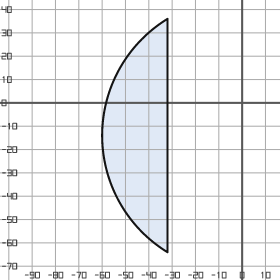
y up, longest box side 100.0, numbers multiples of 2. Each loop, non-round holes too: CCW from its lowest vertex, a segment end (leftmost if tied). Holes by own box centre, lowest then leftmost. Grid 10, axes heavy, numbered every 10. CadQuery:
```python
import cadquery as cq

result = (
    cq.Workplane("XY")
    .moveTo(-32.0, -64.0)
    .lineTo(-32.0, 36.0)
    .threePointArc((-60.0, -14.0), (-32.0, -64.0))
    .close()
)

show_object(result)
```